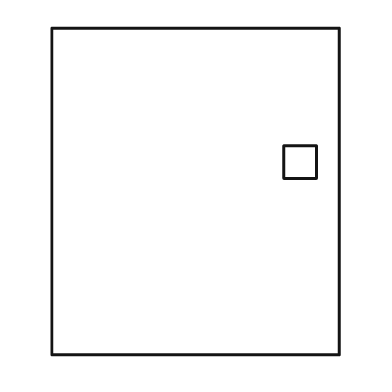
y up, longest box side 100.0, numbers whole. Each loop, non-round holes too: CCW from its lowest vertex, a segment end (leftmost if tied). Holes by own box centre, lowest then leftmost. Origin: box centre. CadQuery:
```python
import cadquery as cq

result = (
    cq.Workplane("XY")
    .moveTo(-44.0, -50.0)
    .lineTo(44.0, -50.0)
    .lineTo(44.0, 50.0)
    .lineTo(-44.0, 50.0)
    .close()
    .moveTo(27.0, 4.0)
    .lineTo(37.0, 4.0)
    .lineTo(37.0, 14.0)
    .lineTo(27.0, 14.0)
    .close()
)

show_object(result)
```